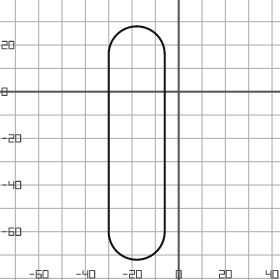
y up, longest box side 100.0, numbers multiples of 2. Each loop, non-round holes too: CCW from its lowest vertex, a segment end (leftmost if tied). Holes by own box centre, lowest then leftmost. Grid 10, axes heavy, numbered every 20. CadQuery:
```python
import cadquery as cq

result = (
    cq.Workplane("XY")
    .moveTo(-30.0, -60.0)
    .threePointArc((-18.0, -72.0), (-6.0, -60.0))
    .lineTo(-6.0, 16.0)
    .threePointArc((-18.0, 28.0), (-30.0, 16.0))
    .close()
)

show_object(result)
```